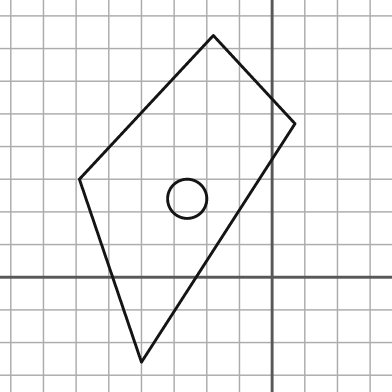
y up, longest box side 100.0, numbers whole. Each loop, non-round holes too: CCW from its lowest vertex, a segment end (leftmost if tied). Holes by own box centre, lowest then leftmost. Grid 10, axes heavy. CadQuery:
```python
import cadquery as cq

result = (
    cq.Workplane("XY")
    .moveTo(-40.0, -26.0)
    .lineTo(7.0, 47.0)
    .lineTo(-18.0, 74.0)
    .lineTo(-59.0, 30.0)
    .close()
    .moveTo(-26.0, 24.0)
    .circle(6.0)
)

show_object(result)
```